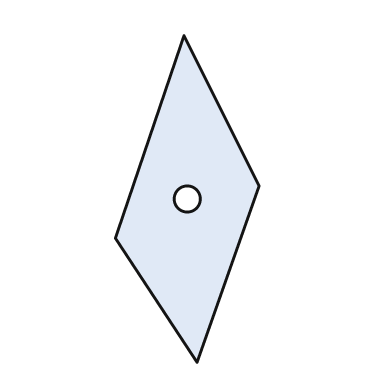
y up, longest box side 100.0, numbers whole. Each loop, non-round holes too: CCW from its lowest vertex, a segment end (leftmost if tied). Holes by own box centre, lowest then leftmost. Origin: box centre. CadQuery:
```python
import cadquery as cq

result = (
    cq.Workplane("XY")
    .moveTo(3.0, -50.0)
    .lineTo(22.0, 4.0)
    .lineTo(-1.0, 50.0)
    .lineTo(-22.0, -12.0)
    .close()
    .moveTo(0.0, 0.0)
    .circle(4.0)
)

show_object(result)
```